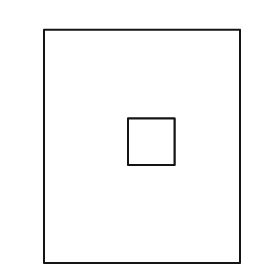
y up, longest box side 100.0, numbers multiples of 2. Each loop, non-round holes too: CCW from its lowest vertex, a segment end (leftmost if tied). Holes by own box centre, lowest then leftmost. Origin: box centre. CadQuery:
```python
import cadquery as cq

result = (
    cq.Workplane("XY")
    .moveTo(-42.0, -50.0)
    .lineTo(42.0, -50.0)
    .lineTo(42.0, 50.0)
    .lineTo(-42.0, 50.0)
    .close()
    .moveTo(-6.0, -8.0)
    .lineTo(14.0, -8.0)
    .lineTo(14.0, 12.0)
    .lineTo(-6.0, 12.0)
    .close()
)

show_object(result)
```